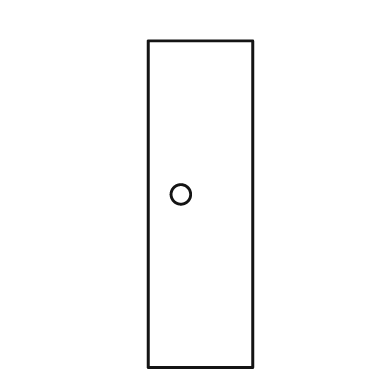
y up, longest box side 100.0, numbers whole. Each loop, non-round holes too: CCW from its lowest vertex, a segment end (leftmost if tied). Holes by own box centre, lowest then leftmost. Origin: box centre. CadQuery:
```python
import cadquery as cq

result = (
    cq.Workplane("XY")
    .moveTo(-16.0, -50.0)
    .lineTo(16.0, -50.0)
    .lineTo(16.0, 50.0)
    .lineTo(-16.0, 50.0)
    .close()
    .moveTo(-6.0, 3.0)
    .circle(3.0)
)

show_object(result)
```